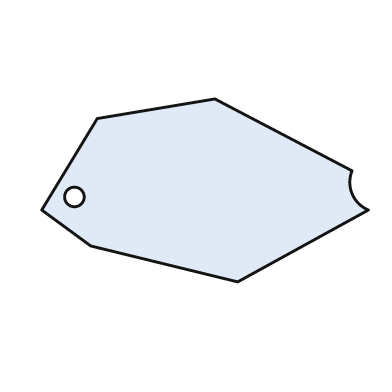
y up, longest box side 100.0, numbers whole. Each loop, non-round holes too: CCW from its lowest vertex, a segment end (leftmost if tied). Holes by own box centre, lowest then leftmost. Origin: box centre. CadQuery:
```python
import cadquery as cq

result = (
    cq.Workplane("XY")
    .moveTo(10.0, -28.0)
    .lineTo(50.0, -6.0)
    .threePointArc((45.0, -1.0), (45.0, 6.0))
    .lineTo(3.0, 28.0)
    .lineTo(-33.0, 22.0)
    .lineTo(-50.0, -6.0)
    .lineTo(-35.0, -17.0)
    .close()
    .moveTo(-40.0, -2.0)
    .circle(3.0)
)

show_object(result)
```